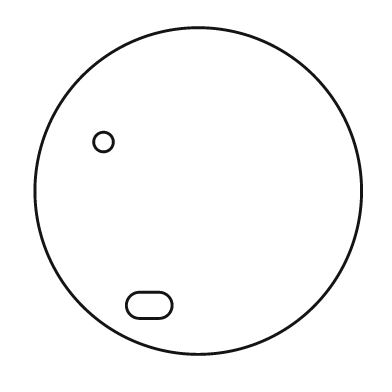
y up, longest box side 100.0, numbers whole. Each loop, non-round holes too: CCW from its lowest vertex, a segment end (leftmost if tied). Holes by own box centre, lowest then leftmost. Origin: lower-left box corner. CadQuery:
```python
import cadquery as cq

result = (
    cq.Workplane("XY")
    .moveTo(50.0, 50.0)
    .circle(50.0)
    .moveTo(32.0, 11.0)
    .lineTo(38.0, 11.0)
    .threePointArc((42.0, 15.0), (38.0, 19.0))
    .lineTo(32.0, 19.0)
    .threePointArc((28.0, 15.0), (32.0, 11.0))
    .close()
    .moveTo(21.0, 65.0)
    .circle(3.0)
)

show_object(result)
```